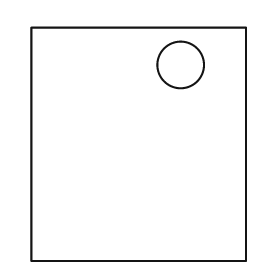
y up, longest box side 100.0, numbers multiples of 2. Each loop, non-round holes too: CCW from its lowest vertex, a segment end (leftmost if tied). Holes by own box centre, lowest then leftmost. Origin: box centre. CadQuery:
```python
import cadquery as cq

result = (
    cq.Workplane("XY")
    .moveTo(-46.0, -50.0)
    .lineTo(46.0, -50.0)
    .lineTo(46.0, 50.0)
    .lineTo(-46.0, 50.0)
    .close()
    .moveTo(18.0, 34.0)
    .circle(10.0)
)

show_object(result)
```